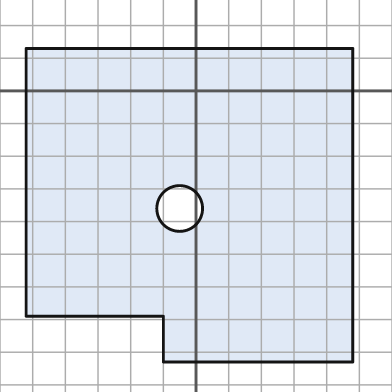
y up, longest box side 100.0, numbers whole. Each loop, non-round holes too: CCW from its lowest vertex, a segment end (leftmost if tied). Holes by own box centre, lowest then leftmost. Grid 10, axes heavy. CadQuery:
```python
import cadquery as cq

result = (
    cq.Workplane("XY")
    .moveTo(-10.0, -83.0)
    .lineTo(48.0, -83.0)
    .lineTo(48.0, 13.0)
    .lineTo(-52.0, 13.0)
    .lineTo(-52.0, -69.0)
    .lineTo(-10.0, -69.0)
    .close()
    .moveTo(-5.0, -36.0)
    .circle(7.0)
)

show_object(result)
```